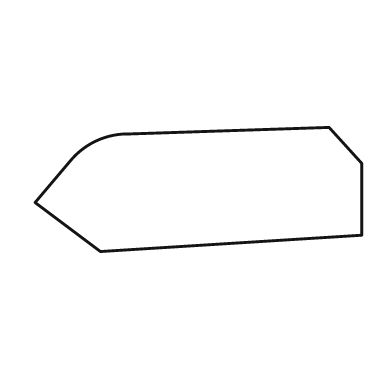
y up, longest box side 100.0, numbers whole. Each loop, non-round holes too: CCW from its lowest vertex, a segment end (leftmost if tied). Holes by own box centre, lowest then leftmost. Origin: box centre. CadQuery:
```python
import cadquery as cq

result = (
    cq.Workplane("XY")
    .moveTo(-30.0, -19.0)
    .lineTo(50.0, -14.0)
    .lineTo(50.0, 8.0)
    .lineTo(40.0, 19.0)
    .lineTo(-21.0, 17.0)
    .threePointArc((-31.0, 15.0), (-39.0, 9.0))
    .lineTo(-50.0, -4.0)
    .close()
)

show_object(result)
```